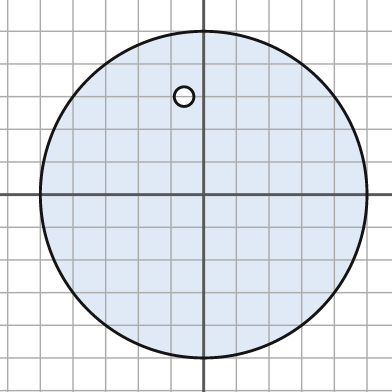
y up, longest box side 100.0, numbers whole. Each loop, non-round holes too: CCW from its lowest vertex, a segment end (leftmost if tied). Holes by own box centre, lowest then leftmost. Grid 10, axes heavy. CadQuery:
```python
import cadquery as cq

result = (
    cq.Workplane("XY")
    .moveTo(0.0, 0.0)
    .circle(50.0)
    .moveTo(-6.0, 30.0)
    .circle(3.0)
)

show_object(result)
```